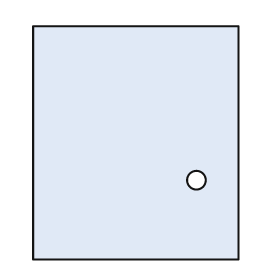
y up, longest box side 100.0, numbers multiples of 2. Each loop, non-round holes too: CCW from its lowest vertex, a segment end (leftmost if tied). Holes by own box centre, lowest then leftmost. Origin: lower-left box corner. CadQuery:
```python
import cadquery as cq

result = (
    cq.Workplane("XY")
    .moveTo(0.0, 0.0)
    .lineTo(88.0, 0.0)
    .lineTo(88.0, 100.0)
    .lineTo(0.0, 100.0)
    .close()
    .moveTo(70.0, 34.0)
    .circle(4.0)
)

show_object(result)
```